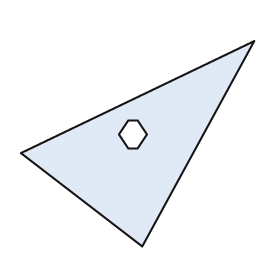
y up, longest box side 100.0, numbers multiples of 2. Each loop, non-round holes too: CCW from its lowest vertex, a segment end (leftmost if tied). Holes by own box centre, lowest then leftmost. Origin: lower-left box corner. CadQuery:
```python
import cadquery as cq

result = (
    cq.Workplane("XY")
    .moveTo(52.0, 0.0)
    .lineTo(100.0, 88.0)
    .lineTo(0.0, 40.0)
    .close()
    .moveTo(46.0, 42.0)
    .lineTo(50.0, 42.0)
    .lineTo(54.0, 48.0)
    .lineTo(50.0, 54.0)
    .lineTo(46.0, 54.0)
    .lineTo(42.0, 48.0)
    .close()
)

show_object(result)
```